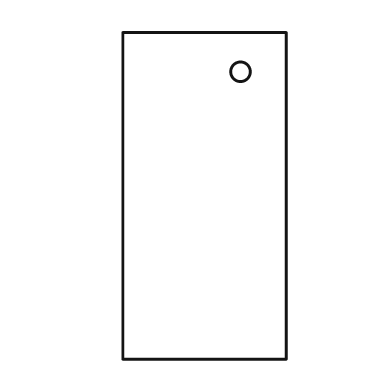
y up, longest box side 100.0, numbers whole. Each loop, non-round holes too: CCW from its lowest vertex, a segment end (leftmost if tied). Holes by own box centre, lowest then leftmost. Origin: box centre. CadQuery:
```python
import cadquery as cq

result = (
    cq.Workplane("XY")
    .moveTo(-25.0, -50.0)
    .lineTo(25.0, -50.0)
    .lineTo(25.0, 50.0)
    .lineTo(-25.0, 50.0)
    .close()
    .moveTo(11.0, 38.0)
    .circle(3.0)
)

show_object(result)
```